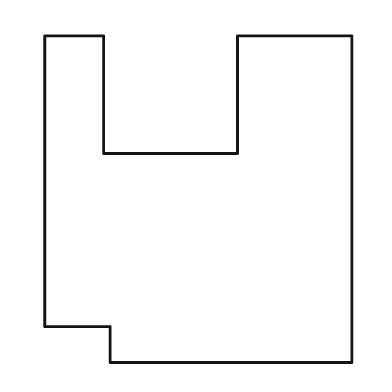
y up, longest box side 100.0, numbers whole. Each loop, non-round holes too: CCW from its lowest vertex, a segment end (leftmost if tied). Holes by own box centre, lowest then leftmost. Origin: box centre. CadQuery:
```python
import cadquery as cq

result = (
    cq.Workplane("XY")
    .moveTo(-27.0, -50.0)
    .lineTo(47.0, -50.0)
    .lineTo(47.0, 50.0)
    .lineTo(12.0, 50.0)
    .lineTo(12.0, 14.0)
    .lineTo(-29.0, 14.0)
    .lineTo(-29.0, 50.0)
    .lineTo(-47.0, 50.0)
    .lineTo(-47.0, -39.0)
    .lineTo(-27.0, -39.0)
    .close()
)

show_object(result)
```